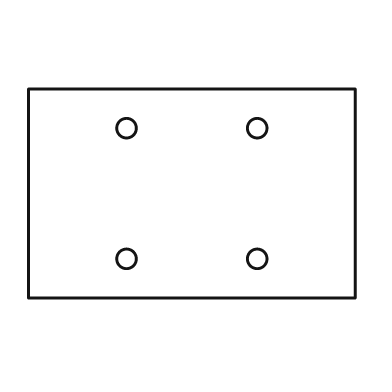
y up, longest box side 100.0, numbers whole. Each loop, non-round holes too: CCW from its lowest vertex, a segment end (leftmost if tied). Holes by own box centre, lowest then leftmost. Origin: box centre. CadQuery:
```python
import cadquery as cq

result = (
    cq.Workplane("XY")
    .moveTo(-50.0, -32.0)
    .lineTo(50.0, -32.0)
    .lineTo(50.0, 32.0)
    .lineTo(-50.0, 32.0)
    .close()
    .moveTo(-20.0, -20.0)
    .circle(3.0)
    .moveTo(20.0, -20.0)
    .circle(3.0)
    .moveTo(-20.0, 20.0)
    .circle(3.0)
    .moveTo(20.0, 20.0)
    .circle(3.0)
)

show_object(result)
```